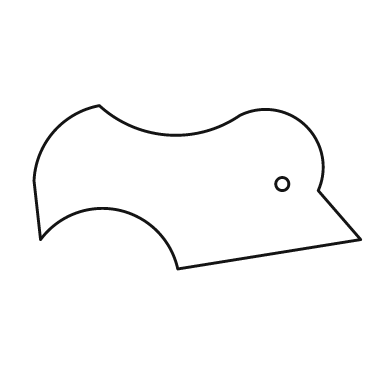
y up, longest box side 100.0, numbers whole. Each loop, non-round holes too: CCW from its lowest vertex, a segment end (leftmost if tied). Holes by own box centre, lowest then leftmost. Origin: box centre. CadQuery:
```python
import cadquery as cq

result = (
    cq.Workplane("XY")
    .moveTo(-6.0, -25.0)
    .lineTo(50.0, -16.0)
    .lineTo(37.0, -1.0)
    .threePointArc((33.0, 19.0), (13.0, 22.0))
    .threePointArc((-9.0, 16.0), (-30.0, 25.0))
    .threePointArc((-44.0, 17.0), (-50.0, 2.0))
    .lineTo(-48.0, -16.0)
    .threePointArc((-24.0, -7.0), (-6.0, -25.0))
    .close()
    .moveTo(26.0, 1.0)
    .circle(2.0)
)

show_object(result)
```